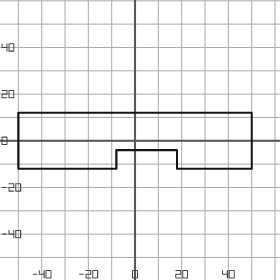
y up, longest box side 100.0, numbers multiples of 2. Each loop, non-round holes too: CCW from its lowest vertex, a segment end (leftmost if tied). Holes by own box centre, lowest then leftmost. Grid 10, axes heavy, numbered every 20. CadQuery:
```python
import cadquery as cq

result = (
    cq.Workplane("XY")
    .moveTo(-50.0, -12.0)
    .lineTo(-8.0, -12.0)
    .lineTo(-8.0, -4.0)
    .lineTo(18.0, -4.0)
    .lineTo(18.0, -12.0)
    .lineTo(50.0, -12.0)
    .lineTo(50.0, 12.0)
    .lineTo(-50.0, 12.0)
    .close()
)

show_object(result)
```